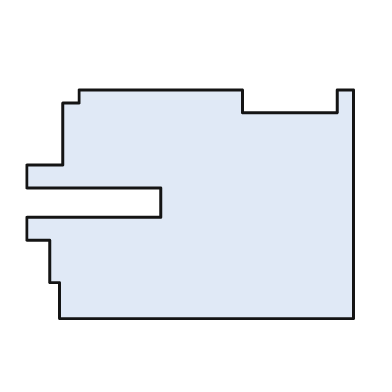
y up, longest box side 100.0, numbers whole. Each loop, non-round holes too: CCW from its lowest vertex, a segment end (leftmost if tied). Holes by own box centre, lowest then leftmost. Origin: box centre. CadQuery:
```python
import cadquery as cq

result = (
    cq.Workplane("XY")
    .moveTo(-40.0, -35.0)
    .lineTo(50.0, -35.0)
    .lineTo(50.0, 35.0)
    .lineTo(45.0, 35.0)
    .lineTo(45.0, 28.0)
    .lineTo(16.0, 28.0)
    .lineTo(16.0, 35.0)
    .lineTo(-34.0, 35.0)
    .lineTo(-34.0, 31.0)
    .lineTo(-39.0, 31.0)
    .lineTo(-39.0, 12.0)
    .lineTo(-50.0, 12.0)
    .lineTo(-50.0, 5.0)
    .lineTo(-9.0, 5.0)
    .lineTo(-9.0, -4.0)
    .lineTo(-50.0, -4.0)
    .lineTo(-50.0, -11.0)
    .lineTo(-43.0, -11.0)
    .lineTo(-43.0, -24.0)
    .lineTo(-40.0, -24.0)
    .close()
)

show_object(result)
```